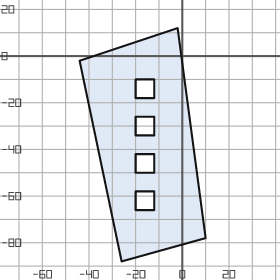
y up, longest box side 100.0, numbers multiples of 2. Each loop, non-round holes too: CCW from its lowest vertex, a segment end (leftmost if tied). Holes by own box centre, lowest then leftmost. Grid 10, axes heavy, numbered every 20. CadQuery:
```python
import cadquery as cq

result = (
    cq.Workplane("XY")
    .moveTo(-26.0, -88.0)
    .lineTo(10.0, -78.0)
    .lineTo(-2.0, 12.0)
    .lineTo(-44.0, -2.0)
    .close()
    .moveTo(-20.0, -66.0)
    .lineTo(-12.0, -66.0)
    .lineTo(-12.0, -58.0)
    .lineTo(-20.0, -58.0)
    .close()
    .moveTo(-20.0, -50.0)
    .lineTo(-12.0, -50.0)
    .lineTo(-12.0, -42.0)
    .lineTo(-20.0, -42.0)
    .close()
    .moveTo(-20.0, -34.0)
    .lineTo(-12.0, -34.0)
    .lineTo(-12.0, -26.0)
    .lineTo(-20.0, -26.0)
    .close()
    .moveTo(-20.0, -18.0)
    .lineTo(-12.0, -18.0)
    .lineTo(-12.0, -10.0)
    .lineTo(-20.0, -10.0)
    .close()
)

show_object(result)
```